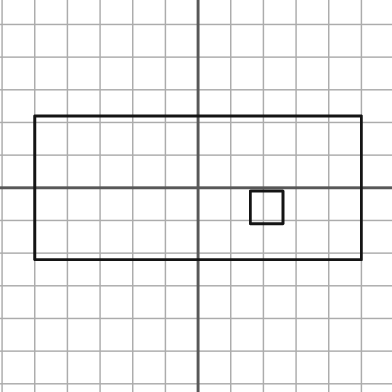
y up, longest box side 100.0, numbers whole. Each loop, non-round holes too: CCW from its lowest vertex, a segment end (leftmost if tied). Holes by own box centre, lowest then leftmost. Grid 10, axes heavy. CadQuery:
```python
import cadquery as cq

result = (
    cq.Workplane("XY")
    .moveTo(-50.0, -22.0)
    .lineTo(50.0, -22.0)
    .lineTo(50.0, 22.0)
    .lineTo(-50.0, 22.0)
    .close()
    .moveTo(16.0, -11.0)
    .lineTo(26.0, -11.0)
    .lineTo(26.0, -1.0)
    .lineTo(16.0, -1.0)
    .close()
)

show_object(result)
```